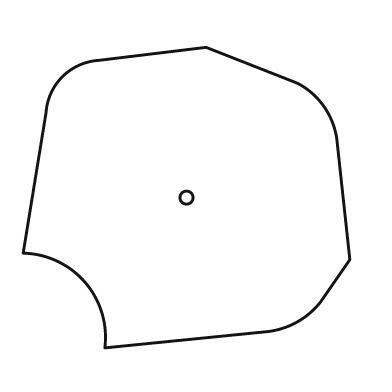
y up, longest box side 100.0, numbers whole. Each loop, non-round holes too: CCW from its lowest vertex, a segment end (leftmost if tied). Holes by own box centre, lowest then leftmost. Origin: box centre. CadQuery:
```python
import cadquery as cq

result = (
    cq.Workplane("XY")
    .moveTo(-25.0, -46.0)
    .lineTo(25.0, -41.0)
    .threePointArc((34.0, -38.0), (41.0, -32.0))
    .lineTo(50.0, -19.0)
    .lineTo(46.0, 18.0)
    .threePointArc((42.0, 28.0), (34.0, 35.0))
    .lineTo(6.0, 46.0)
    .lineTo(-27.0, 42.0)
    .threePointArc((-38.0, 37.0), (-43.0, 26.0))
    .lineTo(-50.0, -17.0)
    .threePointArc((-31.0, -26.0), (-25.0, -46.0))
    .close()
    .moveTo(0.0, 0.0)
    .circle(2.0)
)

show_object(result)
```